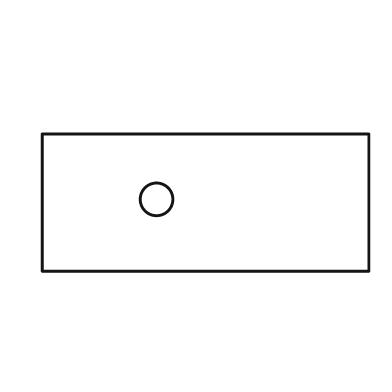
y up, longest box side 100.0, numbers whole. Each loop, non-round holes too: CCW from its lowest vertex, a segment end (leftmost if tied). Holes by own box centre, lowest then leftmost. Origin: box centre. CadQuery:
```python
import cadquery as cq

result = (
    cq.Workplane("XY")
    .moveTo(-50.0, -21.0)
    .lineTo(50.0, -21.0)
    .lineTo(50.0, 21.0)
    .lineTo(-50.0, 21.0)
    .close()
    .moveTo(-15.0, 1.0)
    .circle(5.0)
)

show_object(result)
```